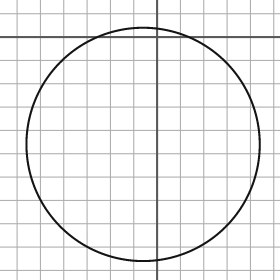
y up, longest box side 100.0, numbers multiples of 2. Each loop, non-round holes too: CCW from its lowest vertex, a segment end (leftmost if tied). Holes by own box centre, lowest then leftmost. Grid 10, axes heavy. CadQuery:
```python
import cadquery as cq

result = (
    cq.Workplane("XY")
    .moveTo(-6.0, -46.0)
    .circle(50.0)
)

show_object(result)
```